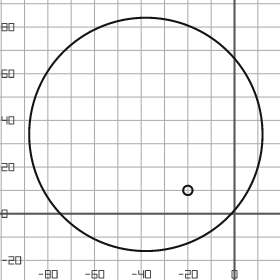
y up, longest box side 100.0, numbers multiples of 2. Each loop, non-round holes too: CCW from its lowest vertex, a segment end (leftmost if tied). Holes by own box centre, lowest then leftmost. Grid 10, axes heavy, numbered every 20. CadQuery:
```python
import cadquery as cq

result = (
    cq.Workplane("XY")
    .moveTo(-38.0, 34.0)
    .circle(50.0)
    .moveTo(-20.0, 10.0)
    .circle(2.0)
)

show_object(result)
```